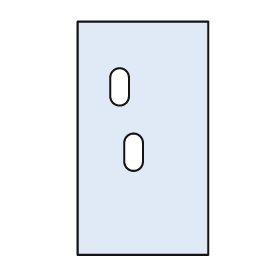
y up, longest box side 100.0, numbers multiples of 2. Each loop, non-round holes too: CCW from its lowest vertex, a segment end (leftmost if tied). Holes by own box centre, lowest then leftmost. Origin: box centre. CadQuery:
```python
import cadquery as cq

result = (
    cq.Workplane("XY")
    .moveTo(-28.0, -50.0)
    .lineTo(28.0, -50.0)
    .lineTo(28.0, 50.0)
    .lineTo(-28.0, 50.0)
    .close()
    .moveTo(-8.0, -10.0)
    .threePointArc((-4.0, -14.0), (0.0, -10.0))
    .lineTo(0.0, -2.0)
    .threePointArc((-4.0, 2.0), (-8.0, -2.0))
    .close()
    .moveTo(-14.0, 18.0)
    .threePointArc((-10.0, 14.0), (-6.0, 18.0))
    .lineTo(-6.0, 26.0)
    .threePointArc((-10.0, 30.0), (-14.0, 26.0))
    .close()
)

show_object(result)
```